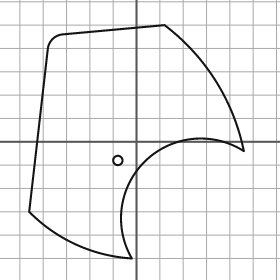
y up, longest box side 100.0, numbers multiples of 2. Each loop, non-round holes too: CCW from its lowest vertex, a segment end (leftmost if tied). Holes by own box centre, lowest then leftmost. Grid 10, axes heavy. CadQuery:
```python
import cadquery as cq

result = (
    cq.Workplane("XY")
    .moveTo(-2.0, -50.0)
    .threePointArc((4.0, -8.0), (46.0, -4.0))
    .threePointArc((34.0, 26.0), (12.0, 50.0))
    .lineTo(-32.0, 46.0)
    .threePointArc((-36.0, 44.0), (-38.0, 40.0))
    .lineTo(-46.0, -30.0)
    .threePointArc((-26.0, -44.0), (-2.0, -50.0))
    .close()
    .moveTo(-8.0, -8.0)
    .circle(2.0)
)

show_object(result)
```